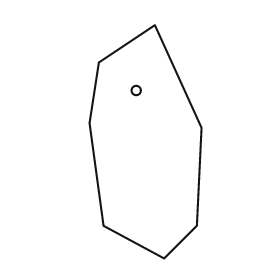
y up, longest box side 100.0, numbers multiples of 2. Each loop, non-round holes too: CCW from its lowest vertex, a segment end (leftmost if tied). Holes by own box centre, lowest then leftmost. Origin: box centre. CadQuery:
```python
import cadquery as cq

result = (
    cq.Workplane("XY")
    .moveTo(8.0, -50.0)
    .lineTo(22.0, -36.0)
    .lineTo(24.0, 6.0)
    .lineTo(4.0, 50.0)
    .lineTo(-20.0, 34.0)
    .lineTo(-24.0, 8.0)
    .lineTo(-18.0, -36.0)
    .close()
    .moveTo(-4.0, 22.0)
    .circle(2.0)
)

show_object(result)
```